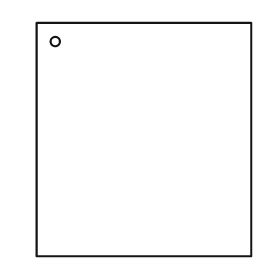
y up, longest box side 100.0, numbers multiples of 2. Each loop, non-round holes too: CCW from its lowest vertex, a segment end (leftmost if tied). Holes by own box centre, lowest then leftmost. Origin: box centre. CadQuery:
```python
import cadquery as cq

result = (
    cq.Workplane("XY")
    .moveTo(-46.0, -50.0)
    .lineTo(46.0, -50.0)
    .lineTo(46.0, 50.0)
    .lineTo(-46.0, 50.0)
    .close()
    .moveTo(-38.0, 42.0)
    .circle(2.0)
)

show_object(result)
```